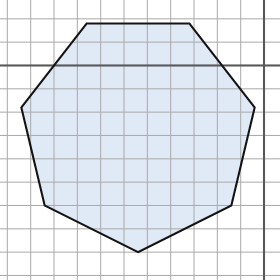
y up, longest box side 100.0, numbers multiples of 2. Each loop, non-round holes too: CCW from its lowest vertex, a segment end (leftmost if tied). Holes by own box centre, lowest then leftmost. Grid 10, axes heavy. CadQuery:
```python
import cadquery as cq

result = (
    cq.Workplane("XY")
    .moveTo(-54.0, -80.0)
    .lineTo(-14.0, -60.0)
    .lineTo(-4.0, -18.0)
    .lineTo(-32.0, 18.0)
    .lineTo(-76.0, 18.0)
    .lineTo(-104.0, -18.0)
    .lineTo(-94.0, -60.0)
    .close()
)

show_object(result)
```